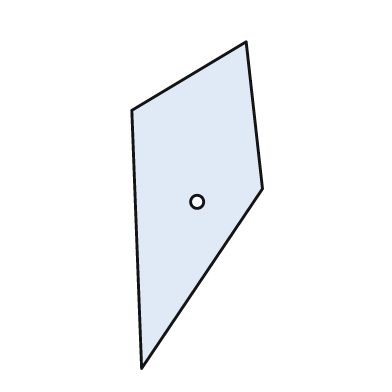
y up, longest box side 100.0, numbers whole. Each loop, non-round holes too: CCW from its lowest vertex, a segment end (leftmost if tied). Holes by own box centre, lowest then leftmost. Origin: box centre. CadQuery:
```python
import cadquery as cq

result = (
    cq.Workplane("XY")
    .moveTo(-17.0, -50.0)
    .lineTo(20.0, 5.0)
    .lineTo(15.0, 50.0)
    .lineTo(-20.0, 29.0)
    .close()
    .moveTo(0.0, 1.0)
    .circle(2.0)
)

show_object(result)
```